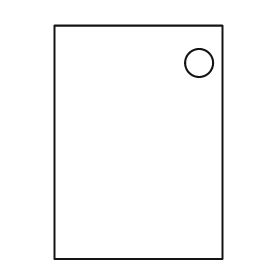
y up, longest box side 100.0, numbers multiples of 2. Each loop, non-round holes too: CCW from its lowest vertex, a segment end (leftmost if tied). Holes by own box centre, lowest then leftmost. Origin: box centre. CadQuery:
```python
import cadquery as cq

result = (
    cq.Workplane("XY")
    .moveTo(-36.0, -50.0)
    .lineTo(36.0, -50.0)
    .lineTo(36.0, 50.0)
    .lineTo(-36.0, 50.0)
    .close()
    .moveTo(26.0, 34.0)
    .circle(6.0)
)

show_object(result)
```